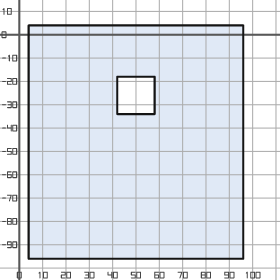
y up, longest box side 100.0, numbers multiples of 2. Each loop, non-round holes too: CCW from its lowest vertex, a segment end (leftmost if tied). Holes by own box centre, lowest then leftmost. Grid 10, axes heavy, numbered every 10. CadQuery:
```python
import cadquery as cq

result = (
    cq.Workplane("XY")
    .moveTo(4.0, -96.0)
    .lineTo(96.0, -96.0)
    .lineTo(96.0, 4.0)
    .lineTo(4.0, 4.0)
    .close()
    .moveTo(42.0, -34.0)
    .lineTo(58.0, -34.0)
    .lineTo(58.0, -18.0)
    .lineTo(42.0, -18.0)
    .close()
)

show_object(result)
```